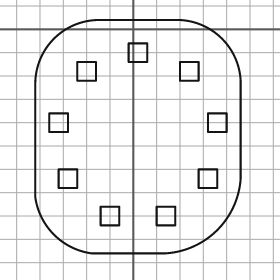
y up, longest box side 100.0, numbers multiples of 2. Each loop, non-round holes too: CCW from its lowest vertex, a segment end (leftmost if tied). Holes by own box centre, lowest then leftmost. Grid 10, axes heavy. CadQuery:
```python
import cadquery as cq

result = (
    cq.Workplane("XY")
    .moveTo(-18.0, -96.0)
    .lineTo(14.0, -96.0)
    .threePointArc((36.0, -86.0), (46.0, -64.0))
    .lineTo(46.0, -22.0)
    .threePointArc((38.0, -4.0), (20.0, 4.0))
    .lineTo(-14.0, 4.0)
    .threePointArc((-34.0, -4.0), (-42.0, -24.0))
    .lineTo(-42.0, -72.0)
    .threePointArc((-34.0, -88.0), (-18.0, -96.0))
    .close()
    .moveTo(-14.0, -84.0)
    .lineTo(-6.0, -84.0)
    .lineTo(-6.0, -76.0)
    .lineTo(-14.0, -76.0)
    .close()
    .moveTo(10.0, -84.0)
    .lineTo(18.0, -84.0)
    .lineTo(18.0, -76.0)
    .lineTo(10.0, -76.0)
    .close()
    .moveTo(-32.0, -68.0)
    .lineTo(-24.0, -68.0)
    .lineTo(-24.0, -60.0)
    .lineTo(-32.0, -60.0)
    .close()
    .moveTo(28.0, -68.0)
    .lineTo(36.0, -68.0)
    .lineTo(36.0, -60.0)
    .lineTo(28.0, -60.0)
    .close()
    .moveTo(-36.0, -44.0)
    .lineTo(-28.0, -44.0)
    .lineTo(-28.0, -36.0)
    .lineTo(-36.0, -36.0)
    .close()
    .moveTo(32.0, -44.0)
    .lineTo(40.0, -44.0)
    .lineTo(40.0, -36.0)
    .lineTo(32.0, -36.0)
    .close()
    .moveTo(-24.0, -22.0)
    .lineTo(-16.0, -22.0)
    .lineTo(-16.0, -14.0)
    .lineTo(-24.0, -14.0)
    .close()
    .moveTo(20.0, -22.0)
    .lineTo(28.0, -22.0)
    .lineTo(28.0, -14.0)
    .lineTo(20.0, -14.0)
    .close()
    .moveTo(-2.0, -14.0)
    .lineTo(6.0, -14.0)
    .lineTo(6.0, -6.0)
    .lineTo(-2.0, -6.0)
    .close()
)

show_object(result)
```